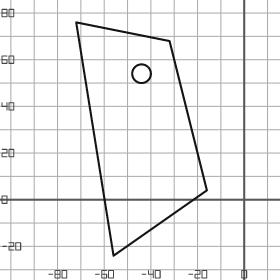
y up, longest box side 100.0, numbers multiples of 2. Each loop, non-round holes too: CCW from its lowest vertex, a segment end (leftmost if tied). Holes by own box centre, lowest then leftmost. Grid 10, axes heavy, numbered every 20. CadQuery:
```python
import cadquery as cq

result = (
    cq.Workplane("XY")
    .moveTo(-56.0, -24.0)
    .lineTo(-16.0, 4.0)
    .lineTo(-32.0, 68.0)
    .lineTo(-72.0, 76.0)
    .close()
    .moveTo(-44.0, 54.0)
    .circle(4.0)
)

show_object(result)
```